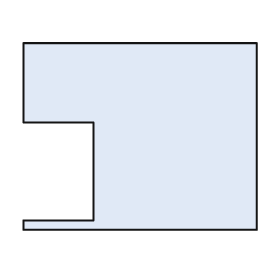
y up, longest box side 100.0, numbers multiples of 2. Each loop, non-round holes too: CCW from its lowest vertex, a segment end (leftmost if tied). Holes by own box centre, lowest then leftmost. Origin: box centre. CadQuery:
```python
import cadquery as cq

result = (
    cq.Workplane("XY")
    .moveTo(-50.0, -40.0)
    .lineTo(50.0, -40.0)
    .lineTo(50.0, 40.0)
    .lineTo(-50.0, 40.0)
    .lineTo(-50.0, 6.0)
    .lineTo(-20.0, 6.0)
    .lineTo(-20.0, -36.0)
    .lineTo(-50.0, -36.0)
    .close()
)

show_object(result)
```